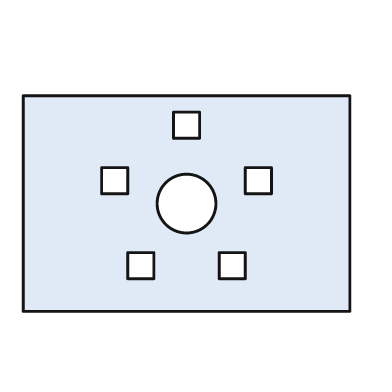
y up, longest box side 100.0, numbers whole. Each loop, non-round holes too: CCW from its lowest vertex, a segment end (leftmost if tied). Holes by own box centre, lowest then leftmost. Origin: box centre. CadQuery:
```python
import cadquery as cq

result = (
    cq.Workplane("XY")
    .moveTo(-50.0, -33.0)
    .lineTo(50.0, -33.0)
    .lineTo(50.0, 33.0)
    .lineTo(-50.0, 33.0)
    .close()
    .moveTo(-18.0, -23.0)
    .lineTo(-10.0, -23.0)
    .lineTo(-10.0, -15.0)
    .lineTo(-18.0, -15.0)
    .close()
    .moveTo(10.0, -23.0)
    .lineTo(18.0, -23.0)
    .lineTo(18.0, -15.0)
    .lineTo(10.0, -15.0)
    .close()
    .moveTo(0.0, 0.0)
    .circle(9.0)
    .moveTo(-26.0, 3.0)
    .lineTo(-18.0, 3.0)
    .lineTo(-18.0, 11.0)
    .lineTo(-26.0, 11.0)
    .close()
    .moveTo(18.0, 3.0)
    .lineTo(26.0, 3.0)
    .lineTo(26.0, 11.0)
    .lineTo(18.0, 11.0)
    .close()
    .moveTo(-4.0, 20.0)
    .lineTo(4.0, 20.0)
    .lineTo(4.0, 28.0)
    .lineTo(-4.0, 28.0)
    .close()
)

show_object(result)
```